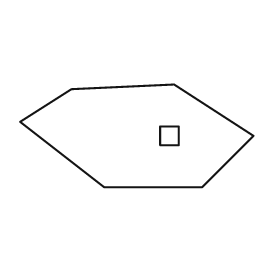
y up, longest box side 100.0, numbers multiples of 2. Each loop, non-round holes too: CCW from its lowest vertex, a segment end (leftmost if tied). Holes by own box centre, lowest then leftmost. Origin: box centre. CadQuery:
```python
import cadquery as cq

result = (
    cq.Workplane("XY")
    .moveTo(-14.0, -22.0)
    .lineTo(28.0, -22.0)
    .lineTo(50.0, 0.0)
    .lineTo(16.0, 22.0)
    .lineTo(-28.0, 20.0)
    .lineTo(-50.0, 6.0)
    .close()
    .moveTo(10.0, -4.0)
    .lineTo(18.0, -4.0)
    .lineTo(18.0, 4.0)
    .lineTo(10.0, 4.0)
    .close()
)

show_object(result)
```